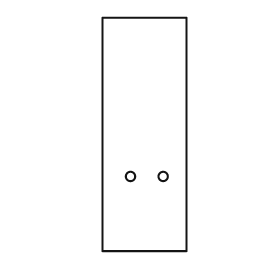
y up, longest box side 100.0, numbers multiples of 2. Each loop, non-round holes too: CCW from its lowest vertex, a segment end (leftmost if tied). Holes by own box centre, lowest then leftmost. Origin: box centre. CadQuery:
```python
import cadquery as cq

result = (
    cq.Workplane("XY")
    .moveTo(-18.0, -50.0)
    .lineTo(18.0, -50.0)
    .lineTo(18.0, 50.0)
    .lineTo(-18.0, 50.0)
    .close()
    .moveTo(-6.0, -18.0)
    .circle(2.0)
    .moveTo(8.0, -18.0)
    .circle(2.0)
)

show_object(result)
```